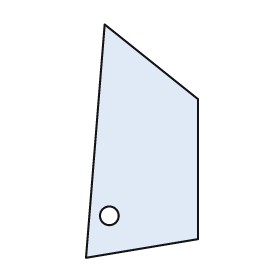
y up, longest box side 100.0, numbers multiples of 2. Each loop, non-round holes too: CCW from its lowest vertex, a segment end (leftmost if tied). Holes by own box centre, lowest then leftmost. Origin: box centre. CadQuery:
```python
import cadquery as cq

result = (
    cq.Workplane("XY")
    .moveTo(-24.0, -50.0)
    .lineTo(24.0, -42.0)
    .lineTo(24.0, 18.0)
    .lineTo(-16.0, 50.0)
    .close()
    .moveTo(-14.0, -32.0)
    .circle(4.0)
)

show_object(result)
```